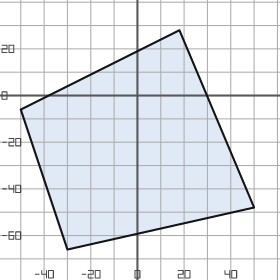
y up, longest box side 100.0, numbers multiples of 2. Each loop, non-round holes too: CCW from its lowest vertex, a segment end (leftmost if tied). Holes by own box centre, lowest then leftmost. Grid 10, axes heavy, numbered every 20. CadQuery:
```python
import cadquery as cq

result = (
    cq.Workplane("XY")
    .moveTo(-30.0, -66.0)
    .lineTo(50.0, -48.0)
    .lineTo(18.0, 28.0)
    .lineTo(-50.0, -6.0)
    .close()
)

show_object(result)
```